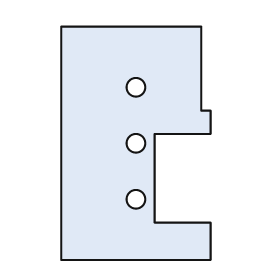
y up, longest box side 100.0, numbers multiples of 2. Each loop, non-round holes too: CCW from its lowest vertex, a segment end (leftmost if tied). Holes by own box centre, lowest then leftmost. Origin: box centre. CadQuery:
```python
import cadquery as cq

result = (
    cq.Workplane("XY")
    .moveTo(-32.0, -50.0)
    .lineTo(32.0, -50.0)
    .lineTo(32.0, -34.0)
    .lineTo(8.0, -34.0)
    .lineTo(8.0, 4.0)
    .lineTo(32.0, 4.0)
    .lineTo(32.0, 14.0)
    .lineTo(28.0, 14.0)
    .lineTo(28.0, 50.0)
    .lineTo(-32.0, 50.0)
    .close()
    .moveTo(0.0, -24.0)
    .circle(4.0)
    .moveTo(0.0, 0.0)
    .circle(4.0)
    .moveTo(0.0, 24.0)
    .circle(4.0)
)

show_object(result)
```